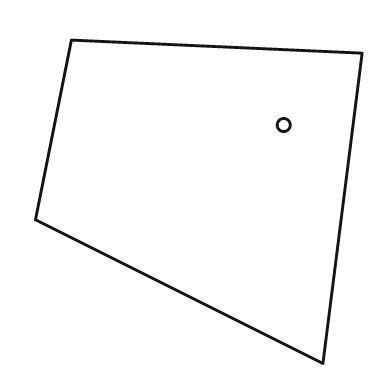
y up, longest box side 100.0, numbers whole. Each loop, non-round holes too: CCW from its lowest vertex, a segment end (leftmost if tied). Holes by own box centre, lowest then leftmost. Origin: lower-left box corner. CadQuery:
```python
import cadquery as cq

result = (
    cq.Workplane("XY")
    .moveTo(88.0, 0.0)
    .lineTo(100.0, 95.0)
    .lineTo(11.0, 99.0)
    .lineTo(0.0, 44.0)
    .close()
    .moveTo(76.0, 73.0)
    .circle(2.0)
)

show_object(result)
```